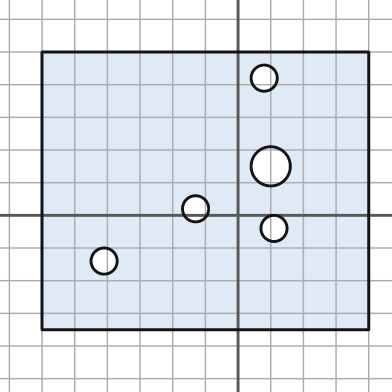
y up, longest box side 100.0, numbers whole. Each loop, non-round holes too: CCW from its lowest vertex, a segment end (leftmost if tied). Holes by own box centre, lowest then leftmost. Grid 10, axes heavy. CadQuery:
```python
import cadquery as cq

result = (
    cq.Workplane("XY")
    .moveTo(-60.0, -35.0)
    .lineTo(40.0, -35.0)
    .lineTo(40.0, 50.0)
    .lineTo(-60.0, 50.0)
    .close()
    .moveTo(-41.0, -14.0)
    .circle(4.0)
    .moveTo(11.0, -4.0)
    .circle(4.0)
    .moveTo(-13.0, 2.0)
    .circle(4.0)
    .moveTo(10.0, 15.0)
    .circle(6.0)
    .moveTo(8.0, 42.0)
    .circle(4.0)
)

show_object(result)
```